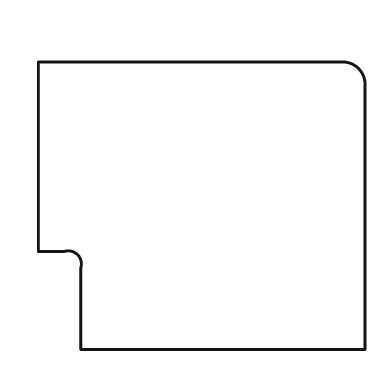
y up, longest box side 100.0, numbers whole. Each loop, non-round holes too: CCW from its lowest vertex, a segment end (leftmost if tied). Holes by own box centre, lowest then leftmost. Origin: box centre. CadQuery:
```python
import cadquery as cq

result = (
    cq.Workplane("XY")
    .moveTo(-37.0, -44.0)
    .lineTo(50.0, -44.0)
    .lineTo(50.0, 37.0)
    .threePointArc((48.0, 42.0), (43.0, 44.0))
    .lineTo(-50.0, 44.0)
    .lineTo(-50.0, -14.0)
    .lineTo(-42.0, -14.0)
    .threePointArc((-38.0, -15.0), (-37.0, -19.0))
    .close()
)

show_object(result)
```